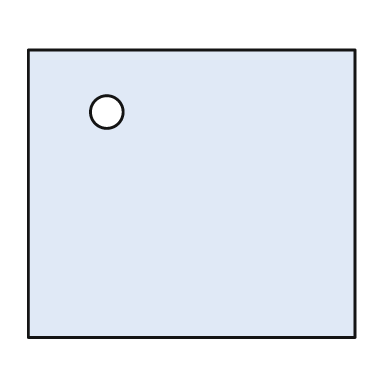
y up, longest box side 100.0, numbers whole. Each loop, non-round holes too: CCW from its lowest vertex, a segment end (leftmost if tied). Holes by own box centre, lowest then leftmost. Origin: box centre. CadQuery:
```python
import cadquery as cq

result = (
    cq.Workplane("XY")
    .moveTo(-50.0, -44.0)
    .lineTo(50.0, -44.0)
    .lineTo(50.0, 44.0)
    .lineTo(-50.0, 44.0)
    .close()
    .moveTo(-26.0, 25.0)
    .circle(5.0)
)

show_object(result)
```